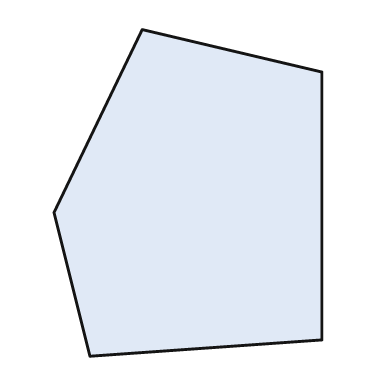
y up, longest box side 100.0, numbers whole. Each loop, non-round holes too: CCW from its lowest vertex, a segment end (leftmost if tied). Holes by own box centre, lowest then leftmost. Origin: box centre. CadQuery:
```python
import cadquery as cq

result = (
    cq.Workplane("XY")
    .moveTo(-30.0, -50.0)
    .lineTo(41.0, -45.0)
    .lineTo(41.0, 37.0)
    .lineTo(-14.0, 50.0)
    .lineTo(-41.0, -6.0)
    .close()
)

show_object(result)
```